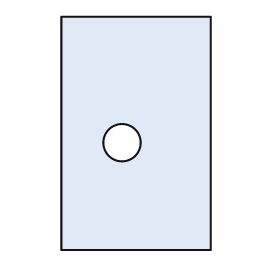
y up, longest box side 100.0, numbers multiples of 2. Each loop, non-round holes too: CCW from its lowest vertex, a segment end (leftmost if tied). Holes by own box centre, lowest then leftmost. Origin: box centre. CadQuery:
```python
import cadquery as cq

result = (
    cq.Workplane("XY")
    .moveTo(-32.0, -50.0)
    .lineTo(32.0, -50.0)
    .lineTo(32.0, 50.0)
    .lineTo(-32.0, 50.0)
    .close()
    .moveTo(-6.0, -4.0)
    .circle(8.0)
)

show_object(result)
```